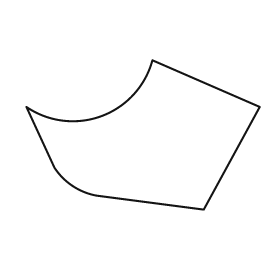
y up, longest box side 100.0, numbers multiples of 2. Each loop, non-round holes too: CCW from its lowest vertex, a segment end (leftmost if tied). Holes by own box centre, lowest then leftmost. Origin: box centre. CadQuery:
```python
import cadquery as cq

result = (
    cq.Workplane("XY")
    .moveTo(26.0, -32.0)
    .lineTo(50.0, 12.0)
    .lineTo(4.0, 32.0)
    .threePointArc((-18.0, 8.0), (-50.0, 12.0))
    .lineTo(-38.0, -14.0)
    .threePointArc((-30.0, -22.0), (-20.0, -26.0))
    .close()
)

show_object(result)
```